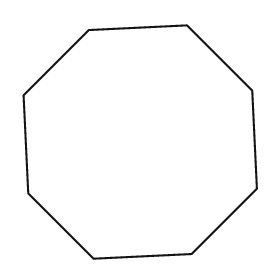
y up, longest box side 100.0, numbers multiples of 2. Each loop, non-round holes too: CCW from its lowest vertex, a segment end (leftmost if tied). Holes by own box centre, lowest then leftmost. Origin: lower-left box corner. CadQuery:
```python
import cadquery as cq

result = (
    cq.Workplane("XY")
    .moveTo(30.0, 0.0)
    .lineTo(72.0, 2.0)
    .lineTo(100.0, 30.0)
    .lineTo(98.0, 72.0)
    .lineTo(70.0, 100.0)
    .lineTo(28.0, 98.0)
    .lineTo(0.0, 70.0)
    .lineTo(2.0, 28.0)
    .close()
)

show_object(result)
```